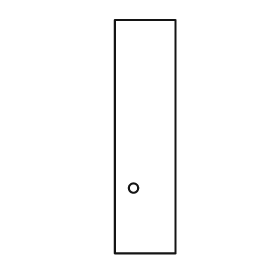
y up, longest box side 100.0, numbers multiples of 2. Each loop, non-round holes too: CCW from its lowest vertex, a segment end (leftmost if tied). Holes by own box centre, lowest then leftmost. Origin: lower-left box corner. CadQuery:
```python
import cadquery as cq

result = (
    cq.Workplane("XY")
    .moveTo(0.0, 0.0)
    .lineTo(26.0, 0.0)
    .lineTo(26.0, 100.0)
    .lineTo(0.0, 100.0)
    .close()
    .moveTo(8.0, 28.0)
    .circle(2.0)
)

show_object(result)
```